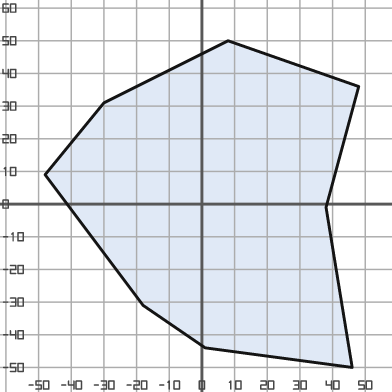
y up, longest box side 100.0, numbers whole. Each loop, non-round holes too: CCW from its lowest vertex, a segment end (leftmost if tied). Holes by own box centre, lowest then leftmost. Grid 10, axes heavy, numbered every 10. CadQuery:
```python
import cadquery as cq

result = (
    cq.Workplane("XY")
    .moveTo(46.0, -50.0)
    .lineTo(38.0, -1.0)
    .lineTo(48.0, 36.0)
    .lineTo(8.0, 50.0)
    .lineTo(-30.0, 31.0)
    .lineTo(-48.0, 9.0)
    .lineTo(-18.0, -31.0)
    .lineTo(1.0, -44.0)
    .close()
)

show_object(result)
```